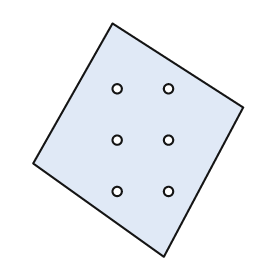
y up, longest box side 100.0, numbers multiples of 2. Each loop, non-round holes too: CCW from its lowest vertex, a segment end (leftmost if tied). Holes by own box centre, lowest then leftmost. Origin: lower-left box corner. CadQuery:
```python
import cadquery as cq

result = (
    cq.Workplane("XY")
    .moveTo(56.0, 0.0)
    .lineTo(90.0, 64.0)
    .lineTo(34.0, 100.0)
    .lineTo(0.0, 40.0)
    .close()
    .moveTo(36.0, 28.0)
    .circle(2.0)
    .moveTo(58.0, 28.0)
    .circle(2.0)
    .moveTo(36.0, 50.0)
    .circle(2.0)
    .moveTo(58.0, 50.0)
    .circle(2.0)
    .moveTo(36.0, 72.0)
    .circle(2.0)
    .moveTo(58.0, 72.0)
    .circle(2.0)
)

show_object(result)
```